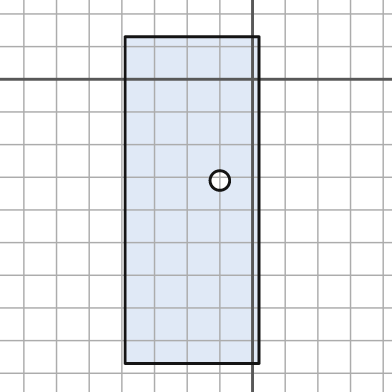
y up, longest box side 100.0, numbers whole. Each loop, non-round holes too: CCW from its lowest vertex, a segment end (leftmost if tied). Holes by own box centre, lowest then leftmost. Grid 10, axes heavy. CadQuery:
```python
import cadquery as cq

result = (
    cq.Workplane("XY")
    .moveTo(-39.0, -87.0)
    .lineTo(2.0, -87.0)
    .lineTo(2.0, 13.0)
    .lineTo(-39.0, 13.0)
    .close()
    .moveTo(-10.0, -31.0)
    .circle(3.0)
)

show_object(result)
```